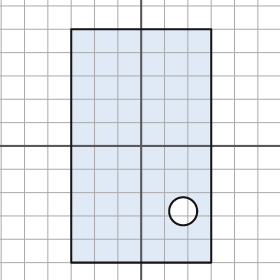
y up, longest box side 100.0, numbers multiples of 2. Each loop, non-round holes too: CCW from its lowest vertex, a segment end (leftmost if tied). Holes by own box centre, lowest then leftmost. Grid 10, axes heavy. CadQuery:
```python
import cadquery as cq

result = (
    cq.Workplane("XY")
    .moveTo(-30.0, -50.0)
    .lineTo(30.0, -50.0)
    .lineTo(30.0, 50.0)
    .lineTo(-30.0, 50.0)
    .close()
    .moveTo(18.0, -28.0)
    .circle(6.0)
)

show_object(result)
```